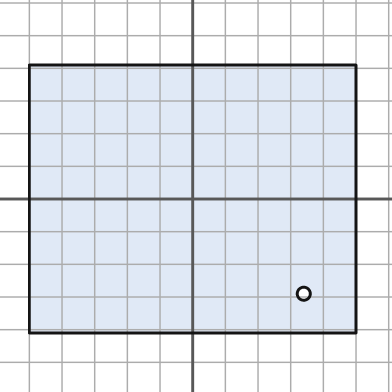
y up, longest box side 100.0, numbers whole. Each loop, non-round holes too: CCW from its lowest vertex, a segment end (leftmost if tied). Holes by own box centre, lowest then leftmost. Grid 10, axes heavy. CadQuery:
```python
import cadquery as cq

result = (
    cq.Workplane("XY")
    .moveTo(-50.0, -41.0)
    .lineTo(50.0, -41.0)
    .lineTo(50.0, 41.0)
    .lineTo(-50.0, 41.0)
    .close()
    .moveTo(34.0, -29.0)
    .circle(2.0)
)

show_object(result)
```